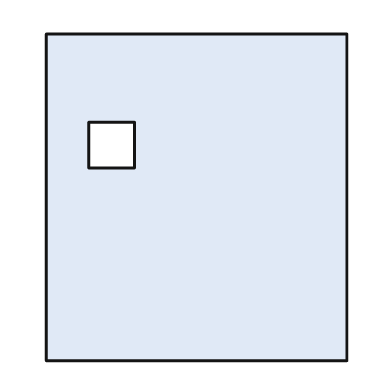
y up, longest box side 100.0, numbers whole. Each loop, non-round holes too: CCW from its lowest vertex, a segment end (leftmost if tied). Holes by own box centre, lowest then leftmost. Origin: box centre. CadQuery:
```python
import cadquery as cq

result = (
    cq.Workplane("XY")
    .moveTo(-46.0, -50.0)
    .lineTo(46.0, -50.0)
    .lineTo(46.0, 50.0)
    .lineTo(-46.0, 50.0)
    .close()
    .moveTo(-33.0, 9.0)
    .lineTo(-19.0, 9.0)
    .lineTo(-19.0, 23.0)
    .lineTo(-33.0, 23.0)
    .close()
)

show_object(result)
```